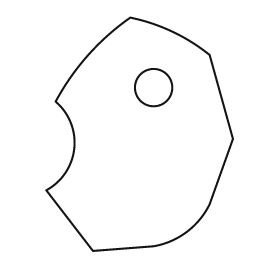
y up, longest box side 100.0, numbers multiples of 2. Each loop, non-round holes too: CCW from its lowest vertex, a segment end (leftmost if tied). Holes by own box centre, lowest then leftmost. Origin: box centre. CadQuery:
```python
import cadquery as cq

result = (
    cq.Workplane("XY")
    .moveTo(-20.0, -50.0)
    .lineTo(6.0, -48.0)
    .threePointArc((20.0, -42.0), (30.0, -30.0))
    .lineTo(40.0, -2.0)
    .lineTo(30.0, 34.0)
    .threePointArc((14.0, 44.0), (-4.0, 50.0))
    .threePointArc((-22.0, 34.0), (-36.0, 14.0))
    .threePointArc((-28.0, -6.0), (-40.0, -24.0))
    .close()
    .moveTo(6.0, 20.0)
    .circle(8.0)
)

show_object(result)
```